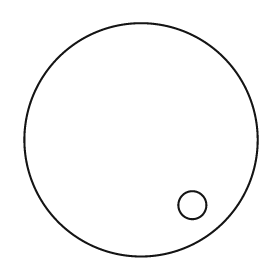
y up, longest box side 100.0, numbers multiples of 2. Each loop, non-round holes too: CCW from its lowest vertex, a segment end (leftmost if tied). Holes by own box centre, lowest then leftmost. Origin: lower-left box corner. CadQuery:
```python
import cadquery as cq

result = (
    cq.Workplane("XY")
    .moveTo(50.0, 50.0)
    .circle(50.0)
    .moveTo(72.0, 22.0)
    .circle(6.0)
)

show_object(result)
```